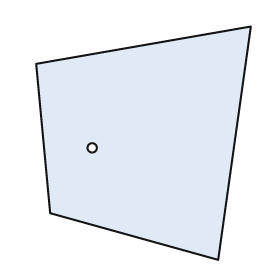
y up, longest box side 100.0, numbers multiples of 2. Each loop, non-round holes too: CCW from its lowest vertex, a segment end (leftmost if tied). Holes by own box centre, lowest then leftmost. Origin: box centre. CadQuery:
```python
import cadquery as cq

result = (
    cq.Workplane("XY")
    .moveTo(32.0, -50.0)
    .lineTo(46.0, 50.0)
    .lineTo(-46.0, 34.0)
    .lineTo(-40.0, -30.0)
    .close()
    .moveTo(-22.0, -2.0)
    .circle(2.0)
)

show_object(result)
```